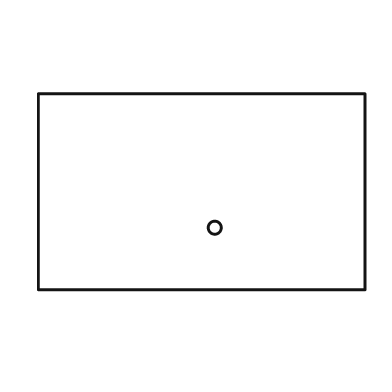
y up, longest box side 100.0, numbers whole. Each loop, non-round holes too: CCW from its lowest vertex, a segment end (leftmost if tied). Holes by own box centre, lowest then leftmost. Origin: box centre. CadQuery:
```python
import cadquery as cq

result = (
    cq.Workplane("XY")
    .moveTo(-50.0, -30.0)
    .lineTo(50.0, -30.0)
    .lineTo(50.0, 30.0)
    .lineTo(-50.0, 30.0)
    .close()
    .moveTo(4.0, -11.0)
    .circle(2.0)
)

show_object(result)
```